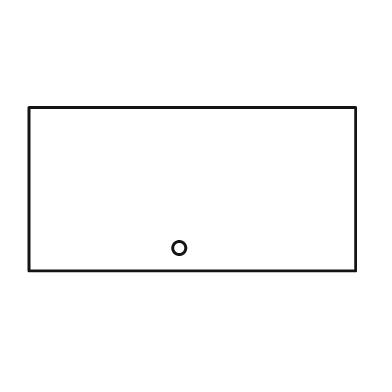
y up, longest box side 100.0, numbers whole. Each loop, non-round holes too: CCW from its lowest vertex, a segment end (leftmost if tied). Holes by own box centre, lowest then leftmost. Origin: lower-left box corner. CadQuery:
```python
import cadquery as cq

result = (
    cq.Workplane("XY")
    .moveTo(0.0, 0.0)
    .lineTo(100.0, 0.0)
    .lineTo(100.0, 50.0)
    .lineTo(0.0, 50.0)
    .close()
    .moveTo(46.0, 7.0)
    .circle(2.0)
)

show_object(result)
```